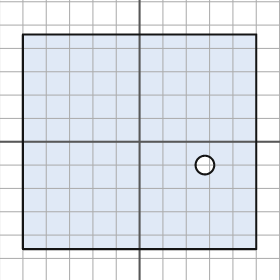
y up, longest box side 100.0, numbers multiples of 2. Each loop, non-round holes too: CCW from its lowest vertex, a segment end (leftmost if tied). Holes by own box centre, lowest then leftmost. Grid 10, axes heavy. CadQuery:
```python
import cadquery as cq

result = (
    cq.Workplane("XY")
    .moveTo(-50.0, -46.0)
    .lineTo(50.0, -46.0)
    .lineTo(50.0, 46.0)
    .lineTo(-50.0, 46.0)
    .close()
    .moveTo(28.0, -10.0)
    .circle(4.0)
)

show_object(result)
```